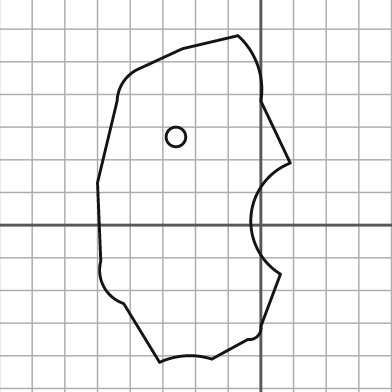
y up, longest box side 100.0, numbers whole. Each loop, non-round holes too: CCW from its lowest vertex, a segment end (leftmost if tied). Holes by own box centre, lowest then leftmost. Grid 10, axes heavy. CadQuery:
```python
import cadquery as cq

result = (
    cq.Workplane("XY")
    .moveTo(-31.0, -42.0)
    .threePointArc((-23.0, -40.0), (-15.0, -41.0))
    .lineTo(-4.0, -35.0)
    .threePointArc((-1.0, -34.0), (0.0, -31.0))
    .lineTo(6.0, -15.0)
    .threePointArc((-3.0, 3.0), (9.0, 19.0))
    .lineTo(0.0, 38.0)
    .threePointArc((-1.0, 49.0), (-7.0, 58.0))
    .lineTo(-24.0, 54.0)
    .lineTo(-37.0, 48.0)
    .threePointArc((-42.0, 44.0), (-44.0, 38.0))
    .lineTo(-50.0, 13.0)
    .lineTo(-49.0, -11.0)
    .threePointArc((-48.0, -19.0), (-42.0, -24.0))
    .close()
    .moveTo(-26.0, 27.0)
    .circle(3.0)
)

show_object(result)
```